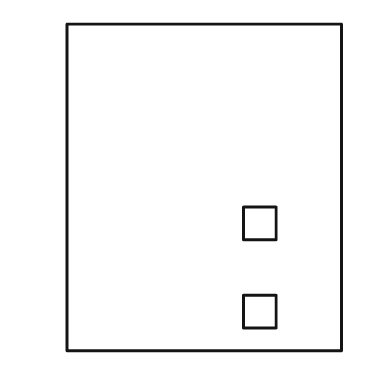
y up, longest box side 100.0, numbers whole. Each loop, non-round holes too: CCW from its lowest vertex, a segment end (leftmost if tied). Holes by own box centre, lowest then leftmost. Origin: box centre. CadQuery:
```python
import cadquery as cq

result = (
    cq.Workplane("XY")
    .moveTo(-42.0, -50.0)
    .lineTo(42.0, -50.0)
    .lineTo(42.0, 50.0)
    .lineTo(-42.0, 50.0)
    .close()
    .moveTo(12.0, -43.0)
    .lineTo(22.0, -43.0)
    .lineTo(22.0, -33.0)
    .lineTo(12.0, -33.0)
    .close()
    .moveTo(12.0, -16.0)
    .lineTo(22.0, -16.0)
    .lineTo(22.0, -6.0)
    .lineTo(12.0, -6.0)
    .close()
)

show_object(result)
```